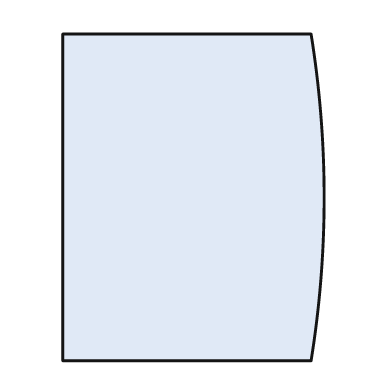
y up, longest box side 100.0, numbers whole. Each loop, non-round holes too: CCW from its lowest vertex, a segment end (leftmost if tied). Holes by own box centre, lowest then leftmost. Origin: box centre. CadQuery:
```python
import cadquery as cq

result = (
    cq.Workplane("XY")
    .moveTo(-40.0, -50.0)
    .lineTo(36.0, -50.0)
    .threePointArc((40.0, 0.0), (36.0, 50.0))
    .lineTo(-40.0, 50.0)
    .close()
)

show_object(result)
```